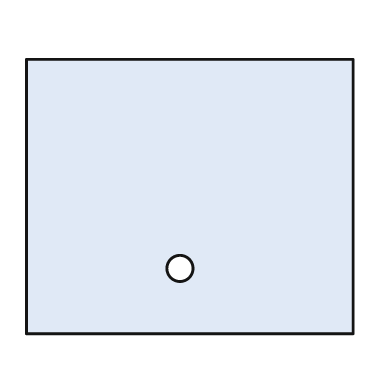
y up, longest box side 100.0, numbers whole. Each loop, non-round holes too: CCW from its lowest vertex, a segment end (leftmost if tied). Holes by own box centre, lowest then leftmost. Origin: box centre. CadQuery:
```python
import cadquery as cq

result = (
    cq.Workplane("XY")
    .moveTo(-50.0, -42.0)
    .lineTo(50.0, -42.0)
    .lineTo(50.0, 42.0)
    .lineTo(-50.0, 42.0)
    .close()
    .moveTo(-3.0, -22.0)
    .circle(4.0)
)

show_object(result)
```